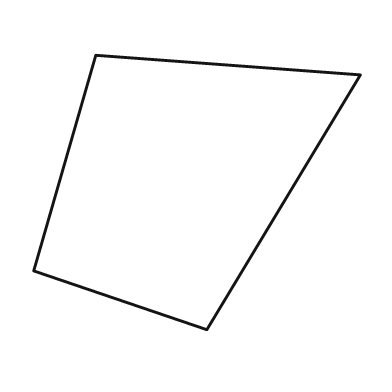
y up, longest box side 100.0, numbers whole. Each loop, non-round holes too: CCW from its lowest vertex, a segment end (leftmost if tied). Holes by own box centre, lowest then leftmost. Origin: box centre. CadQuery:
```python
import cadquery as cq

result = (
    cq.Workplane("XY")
    .moveTo(3.0, -42.0)
    .lineTo(50.0, 36.0)
    .lineTo(-31.0, 42.0)
    .lineTo(-50.0, -24.0)
    .close()
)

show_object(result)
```